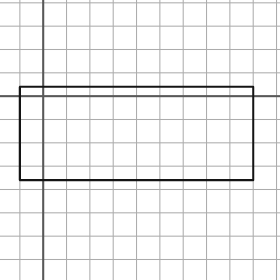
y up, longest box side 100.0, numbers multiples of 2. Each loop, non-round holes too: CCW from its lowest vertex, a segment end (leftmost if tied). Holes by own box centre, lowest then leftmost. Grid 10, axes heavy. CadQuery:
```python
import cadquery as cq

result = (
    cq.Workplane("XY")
    .moveTo(-10.0, -36.0)
    .lineTo(90.0, -36.0)
    .lineTo(90.0, 4.0)
    .lineTo(-10.0, 4.0)
    .close()
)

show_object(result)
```